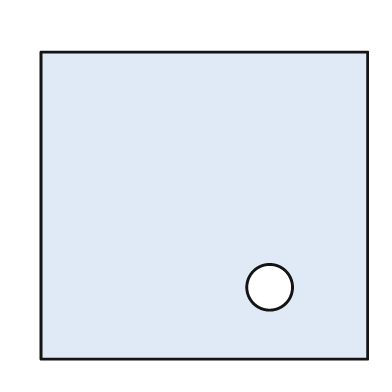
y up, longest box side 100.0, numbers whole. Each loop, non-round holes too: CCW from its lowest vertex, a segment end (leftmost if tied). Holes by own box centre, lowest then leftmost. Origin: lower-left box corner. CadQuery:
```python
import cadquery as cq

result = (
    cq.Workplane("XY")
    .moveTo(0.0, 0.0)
    .lineTo(100.0, 0.0)
    .lineTo(100.0, 94.0)
    .lineTo(0.0, 94.0)
    .close()
    .moveTo(70.0, 22.0)
    .circle(7.0)
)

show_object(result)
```